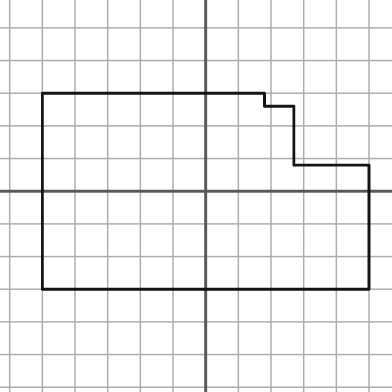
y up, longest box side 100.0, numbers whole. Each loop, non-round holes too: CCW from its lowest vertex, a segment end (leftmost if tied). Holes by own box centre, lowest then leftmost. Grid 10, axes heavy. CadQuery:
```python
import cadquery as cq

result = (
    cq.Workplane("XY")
    .moveTo(-50.0, -30.0)
    .lineTo(50.0, -30.0)
    .lineTo(50.0, 8.0)
    .lineTo(27.0, 8.0)
    .lineTo(27.0, 26.0)
    .lineTo(18.0, 26.0)
    .lineTo(18.0, 30.0)
    .lineTo(-50.0, 30.0)
    .close()
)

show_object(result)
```